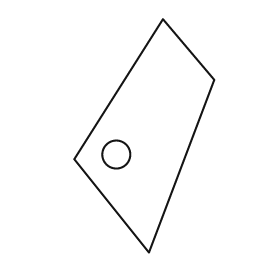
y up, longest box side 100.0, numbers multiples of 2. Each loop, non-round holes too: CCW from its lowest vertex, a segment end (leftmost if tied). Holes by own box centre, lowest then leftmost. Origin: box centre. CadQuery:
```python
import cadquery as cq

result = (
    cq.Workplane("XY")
    .moveTo(2.0, -50.0)
    .lineTo(30.0, 24.0)
    .lineTo(8.0, 50.0)
    .lineTo(-30.0, -10.0)
    .close()
    .moveTo(-12.0, -8.0)
    .circle(6.0)
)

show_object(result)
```